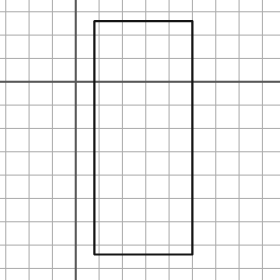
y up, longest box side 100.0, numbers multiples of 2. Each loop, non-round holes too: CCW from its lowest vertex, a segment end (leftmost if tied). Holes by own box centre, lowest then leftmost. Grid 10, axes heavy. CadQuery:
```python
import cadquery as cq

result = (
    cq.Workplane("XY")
    .moveTo(8.0, -74.0)
    .lineTo(50.0, -74.0)
    .lineTo(50.0, 26.0)
    .lineTo(8.0, 26.0)
    .close()
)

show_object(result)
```